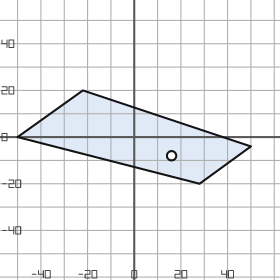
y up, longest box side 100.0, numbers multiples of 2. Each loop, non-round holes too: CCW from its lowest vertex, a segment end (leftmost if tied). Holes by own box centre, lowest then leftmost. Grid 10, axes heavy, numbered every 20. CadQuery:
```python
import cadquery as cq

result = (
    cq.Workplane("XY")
    .moveTo(28.0, -20.0)
    .lineTo(50.0, -4.0)
    .lineTo(-22.0, 20.0)
    .lineTo(-50.0, 0.0)
    .close()
    .moveTo(16.0, -8.0)
    .circle(2.0)
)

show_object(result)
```